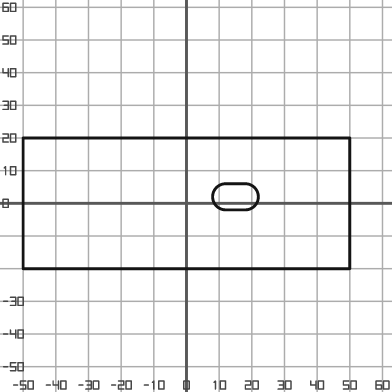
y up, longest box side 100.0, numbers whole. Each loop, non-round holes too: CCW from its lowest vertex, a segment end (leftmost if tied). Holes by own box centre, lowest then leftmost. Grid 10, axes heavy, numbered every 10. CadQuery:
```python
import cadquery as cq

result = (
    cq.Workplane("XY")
    .moveTo(-50.0, -20.0)
    .lineTo(50.0, -20.0)
    .lineTo(50.0, 20.0)
    .lineTo(-50.0, 20.0)
    .close()
    .moveTo(12.0, -2.0)
    .lineTo(18.0, -2.0)
    .threePointArc((22.0, 2.0), (18.0, 6.0))
    .lineTo(12.0, 6.0)
    .threePointArc((8.0, 2.0), (12.0, -2.0))
    .close()
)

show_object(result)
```